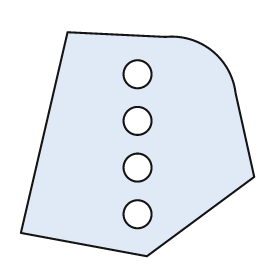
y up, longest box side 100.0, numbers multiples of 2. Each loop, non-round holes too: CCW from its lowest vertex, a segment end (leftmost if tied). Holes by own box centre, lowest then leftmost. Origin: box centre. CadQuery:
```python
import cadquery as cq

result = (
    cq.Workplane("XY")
    .moveTo(4.0, -48.0)
    .lineTo(50.0, -14.0)
    .lineTo(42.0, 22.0)
    .threePointArc((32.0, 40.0), (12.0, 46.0))
    .lineTo(-30.0, 48.0)
    .lineTo(-50.0, -38.0)
    .close()
    .moveTo(0.0, -30.0)
    .circle(6.0)
    .moveTo(0.0, -10.0)
    .circle(6.0)
    .moveTo(0.0, 10.0)
    .circle(6.0)
    .moveTo(0.0, 30.0)
    .circle(6.0)
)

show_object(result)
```